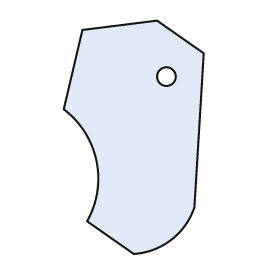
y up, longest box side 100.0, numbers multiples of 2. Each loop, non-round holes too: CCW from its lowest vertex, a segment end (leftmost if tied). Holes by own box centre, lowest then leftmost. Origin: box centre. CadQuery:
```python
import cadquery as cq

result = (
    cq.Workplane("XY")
    .moveTo(0.0, -50.0)
    .threePointArc((16.0, -44.0), (26.0, -30.0))
    .lineTo(30.0, 36.0)
    .lineTo(10.0, 50.0)
    .lineTo(-22.0, 46.0)
    .lineTo(-30.0, 12.0)
    .threePointArc((-16.0, -10.0), (-20.0, -36.0))
    .close()
    .moveTo(14.0, 26.0)
    .circle(4.0)
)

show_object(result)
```